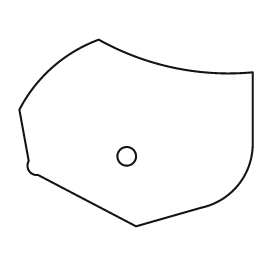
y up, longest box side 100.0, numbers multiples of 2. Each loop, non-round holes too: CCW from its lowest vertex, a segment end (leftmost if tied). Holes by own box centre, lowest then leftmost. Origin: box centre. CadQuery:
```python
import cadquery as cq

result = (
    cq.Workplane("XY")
    .moveTo(0.0, -40.0)
    .lineTo(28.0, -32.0)
    .threePointArc((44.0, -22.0), (50.0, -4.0))
    .lineTo(50.0, 26.0)
    .threePointArc((16.0, 28.0), (-16.0, 40.0))
    .threePointArc((-36.0, 28.0), (-50.0, 10.0))
    .lineTo(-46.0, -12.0)
    .threePointArc((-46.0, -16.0), (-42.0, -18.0))
    .close()
    .moveTo(-4.0, -10.0)
    .circle(4.0)
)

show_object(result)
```